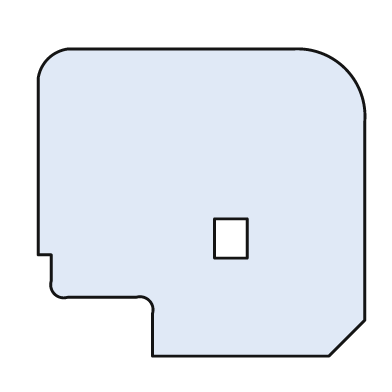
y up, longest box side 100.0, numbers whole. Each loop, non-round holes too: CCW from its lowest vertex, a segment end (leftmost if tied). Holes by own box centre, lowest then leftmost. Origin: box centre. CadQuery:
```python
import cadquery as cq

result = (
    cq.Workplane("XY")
    .moveTo(-15.0, -47.0)
    .lineTo(39.0, -47.0)
    .lineTo(50.0, -36.0)
    .lineTo(50.0, 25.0)
    .threePointArc((44.0, 41.0), (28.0, 47.0))
    .lineTo(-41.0, 47.0)
    .threePointArc((-47.0, 44.0), (-50.0, 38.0))
    .lineTo(-50.0, -16.0)
    .lineTo(-46.0, -16.0)
    .lineTo(-46.0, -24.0)
    .threePointArc((-45.0, -28.0), (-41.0, -29.0))
    .lineTo(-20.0, -29.0)
    .threePointArc((-16.0, -30.0), (-15.0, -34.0))
    .close()
    .moveTo(4.0, -17.0)
    .lineTo(14.0, -17.0)
    .lineTo(14.0, -5.0)
    .lineTo(4.0, -5.0)
    .close()
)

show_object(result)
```